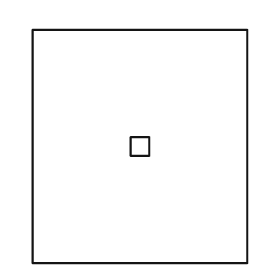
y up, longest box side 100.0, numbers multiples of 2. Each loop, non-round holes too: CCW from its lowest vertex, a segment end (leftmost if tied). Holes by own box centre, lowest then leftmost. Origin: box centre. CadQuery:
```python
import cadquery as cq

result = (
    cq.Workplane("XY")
    .moveTo(-46.0, -50.0)
    .lineTo(46.0, -50.0)
    .lineTo(46.0, 50.0)
    .lineTo(-46.0, 50.0)
    .close()
    .moveTo(-4.0, -4.0)
    .lineTo(4.0, -4.0)
    .lineTo(4.0, 4.0)
    .lineTo(-4.0, 4.0)
    .close()
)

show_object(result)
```